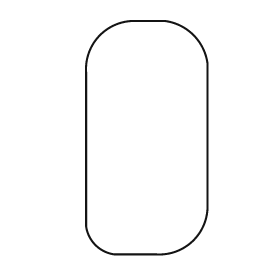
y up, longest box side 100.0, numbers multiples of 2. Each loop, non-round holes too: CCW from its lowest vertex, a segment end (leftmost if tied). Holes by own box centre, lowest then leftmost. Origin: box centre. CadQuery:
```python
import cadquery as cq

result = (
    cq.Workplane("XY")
    .moveTo(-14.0, -50.0)
    .lineTo(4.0, -50.0)
    .threePointArc((20.0, -44.0), (26.0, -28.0))
    .lineTo(26.0, 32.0)
    .threePointArc((20.0, 44.0), (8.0, 50.0))
    .lineTo(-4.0, 50.0)
    .threePointArc((-20.0, 44.0), (-26.0, 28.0))
    .lineTo(-26.0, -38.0)
    .threePointArc((-22.0, -46.0), (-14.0, -50.0))
    .close()
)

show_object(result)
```